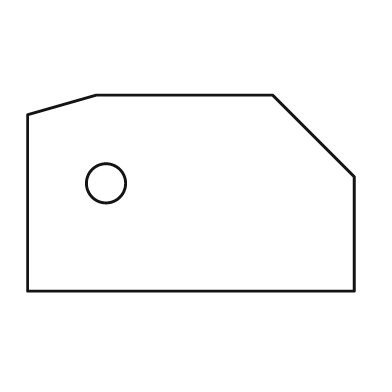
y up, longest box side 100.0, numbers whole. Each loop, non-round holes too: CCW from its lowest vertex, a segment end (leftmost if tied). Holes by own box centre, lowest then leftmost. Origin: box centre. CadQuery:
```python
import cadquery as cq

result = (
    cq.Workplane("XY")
    .moveTo(-50.0, -30.0)
    .lineTo(50.0, -30.0)
    .lineTo(50.0, 5.0)
    .lineTo(25.0, 30.0)
    .lineTo(-29.0, 30.0)
    .lineTo(-50.0, 24.0)
    .close()
    .moveTo(-26.0, 3.0)
    .circle(6.0)
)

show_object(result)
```